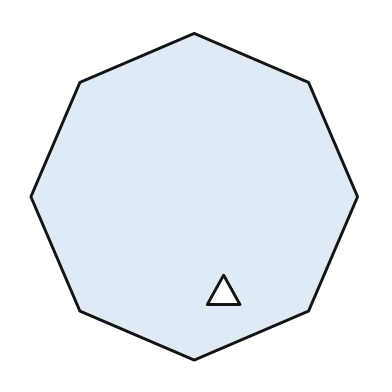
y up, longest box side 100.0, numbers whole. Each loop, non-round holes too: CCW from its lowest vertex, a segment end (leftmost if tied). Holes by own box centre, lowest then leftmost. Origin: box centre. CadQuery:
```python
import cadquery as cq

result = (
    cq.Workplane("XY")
    .moveTo(0.0, -50.0)
    .lineTo(35.0, -35.0)
    .lineTo(50.0, 0.0)
    .lineTo(35.0, 35.0)
    .lineTo(0.0, 50.0)
    .lineTo(-35.0, 35.0)
    .lineTo(-50.0, 0.0)
    .lineTo(-35.0, -35.0)
    .close()
    .moveTo(4.0, -33.0)
    .lineTo(14.0, -33.0)
    .lineTo(9.0, -24.0)
    .close()
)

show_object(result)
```